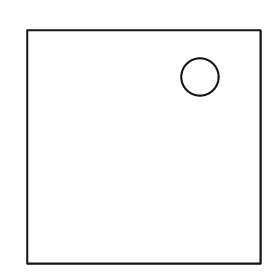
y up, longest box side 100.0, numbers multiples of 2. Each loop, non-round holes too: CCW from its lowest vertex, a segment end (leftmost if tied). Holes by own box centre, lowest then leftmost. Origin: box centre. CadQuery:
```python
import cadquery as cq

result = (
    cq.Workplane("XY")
    .moveTo(-50.0, -50.0)
    .lineTo(50.0, -50.0)
    .lineTo(50.0, 50.0)
    .lineTo(-50.0, 50.0)
    .close()
    .moveTo(24.0, 30.0)
    .circle(8.0)
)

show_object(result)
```